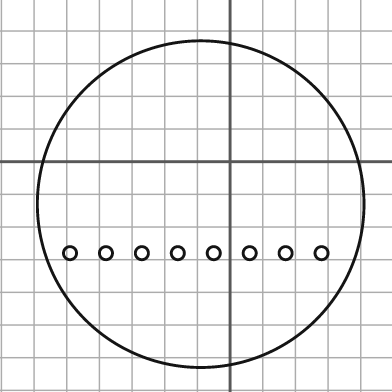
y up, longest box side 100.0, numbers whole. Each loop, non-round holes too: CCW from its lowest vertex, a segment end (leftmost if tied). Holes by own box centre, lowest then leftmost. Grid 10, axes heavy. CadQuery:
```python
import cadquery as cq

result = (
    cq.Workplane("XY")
    .moveTo(-9.0, -13.0)
    .circle(50.0)
    .moveTo(-49.0, -28.0)
    .circle(2.0)
    .moveTo(-38.0, -28.0)
    .circle(2.0)
    .moveTo(-27.0, -28.0)
    .circle(2.0)
    .moveTo(-16.0, -28.0)
    .circle(2.0)
    .moveTo(-5.0, -28.0)
    .circle(2.0)
    .moveTo(6.0, -28.0)
    .circle(2.0)
    .moveTo(17.0, -28.0)
    .circle(2.0)
    .moveTo(28.0, -28.0)
    .circle(2.0)
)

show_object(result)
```